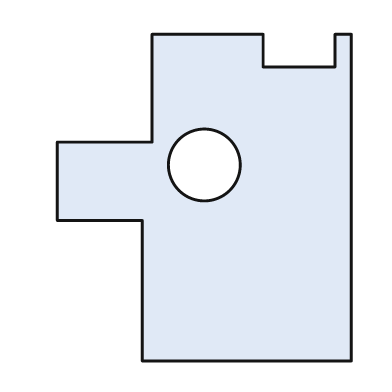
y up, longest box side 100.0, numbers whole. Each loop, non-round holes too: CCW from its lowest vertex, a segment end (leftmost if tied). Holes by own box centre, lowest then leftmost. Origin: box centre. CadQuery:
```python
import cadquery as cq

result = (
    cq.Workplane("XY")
    .moveTo(-19.0, -50.0)
    .lineTo(45.0, -50.0)
    .lineTo(45.0, 50.0)
    .lineTo(40.0, 50.0)
    .lineTo(40.0, 40.0)
    .lineTo(18.0, 40.0)
    .lineTo(18.0, 50.0)
    .lineTo(-16.0, 50.0)
    .lineTo(-16.0, 17.0)
    .lineTo(-45.0, 17.0)
    .lineTo(-45.0, -7.0)
    .lineTo(-19.0, -7.0)
    .close()
    .moveTo(0.0, 10.0)
    .circle(11.0)
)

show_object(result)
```